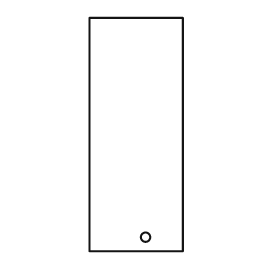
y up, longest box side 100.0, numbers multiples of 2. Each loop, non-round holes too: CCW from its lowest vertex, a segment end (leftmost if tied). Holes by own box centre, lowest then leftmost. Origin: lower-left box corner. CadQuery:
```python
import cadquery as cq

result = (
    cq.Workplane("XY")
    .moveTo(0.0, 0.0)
    .lineTo(40.0, 0.0)
    .lineTo(40.0, 100.0)
    .lineTo(0.0, 100.0)
    .close()
    .moveTo(24.0, 6.0)
    .circle(2.0)
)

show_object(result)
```